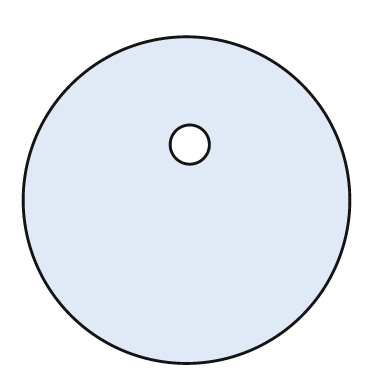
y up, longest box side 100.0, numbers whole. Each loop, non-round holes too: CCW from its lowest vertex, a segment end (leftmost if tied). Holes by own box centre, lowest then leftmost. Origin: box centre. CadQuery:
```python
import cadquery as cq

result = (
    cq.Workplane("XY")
    .moveTo(0.0, 0.0)
    .circle(50.0)
    .moveTo(1.0, 17.0)
    .circle(6.0)
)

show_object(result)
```